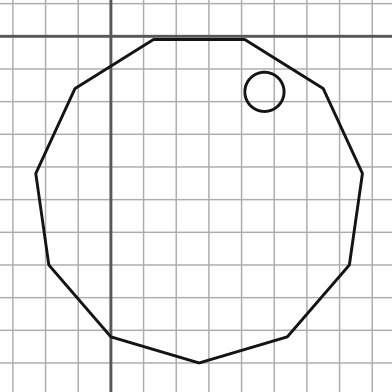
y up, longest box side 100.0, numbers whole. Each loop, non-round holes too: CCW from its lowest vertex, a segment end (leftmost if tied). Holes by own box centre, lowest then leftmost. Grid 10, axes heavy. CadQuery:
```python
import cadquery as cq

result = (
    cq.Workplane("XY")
    .moveTo(27.0, -100.0)
    .lineTo(54.0, -92.0)
    .lineTo(73.0, -70.0)
    .lineTo(77.0, -42.0)
    .lineTo(65.0, -16.0)
    .lineTo(41.0, -1.0)
    .lineTo(13.0, -1.0)
    .lineTo(-11.0, -16.0)
    .lineTo(-23.0, -42.0)
    .lineTo(-19.0, -70.0)
    .lineTo(0.0, -92.0)
    .close()
    .moveTo(47.0, -17.0)
    .circle(6.0)
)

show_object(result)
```